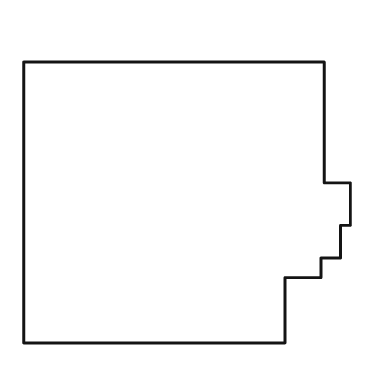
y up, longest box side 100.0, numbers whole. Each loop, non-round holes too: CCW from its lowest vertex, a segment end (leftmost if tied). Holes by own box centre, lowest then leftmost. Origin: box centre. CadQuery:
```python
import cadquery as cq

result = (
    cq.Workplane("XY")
    .moveTo(-50.0, -43.0)
    .lineTo(30.0, -43.0)
    .lineTo(30.0, -23.0)
    .lineTo(41.0, -23.0)
    .lineTo(41.0, -17.0)
    .lineTo(47.0, -17.0)
    .lineTo(47.0, -7.0)
    .lineTo(50.0, -7.0)
    .lineTo(50.0, 6.0)
    .lineTo(42.0, 6.0)
    .lineTo(42.0, 43.0)
    .lineTo(-50.0, 43.0)
    .close()
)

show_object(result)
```